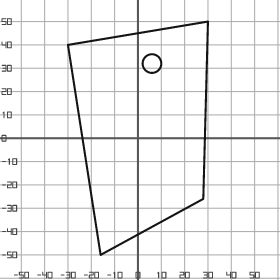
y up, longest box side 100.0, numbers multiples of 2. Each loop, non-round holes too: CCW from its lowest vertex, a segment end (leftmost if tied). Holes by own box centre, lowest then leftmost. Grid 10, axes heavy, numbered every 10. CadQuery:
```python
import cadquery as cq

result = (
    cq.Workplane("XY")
    .moveTo(-16.0, -50.0)
    .lineTo(28.0, -26.0)
    .lineTo(30.0, 50.0)
    .lineTo(-30.0, 40.0)
    .close()
    .moveTo(6.0, 32.0)
    .circle(4.0)
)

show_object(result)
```